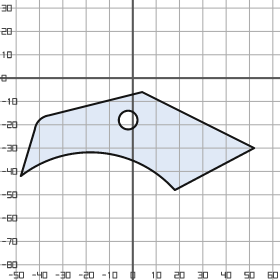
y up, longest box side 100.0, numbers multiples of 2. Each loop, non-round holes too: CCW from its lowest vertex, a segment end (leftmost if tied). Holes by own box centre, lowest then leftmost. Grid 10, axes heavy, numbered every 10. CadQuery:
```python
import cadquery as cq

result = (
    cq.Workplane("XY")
    .moveTo(18.0, -48.0)
    .lineTo(52.0, -30.0)
    .lineTo(4.0, -6.0)
    .lineTo(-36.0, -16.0)
    .threePointArc((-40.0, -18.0), (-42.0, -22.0))
    .lineTo(-48.0, -42.0)
    .threePointArc((-14.0, -32.0), (18.0, -48.0))
    .close()
    .moveTo(-2.0, -18.0)
    .circle(4.0)
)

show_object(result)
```